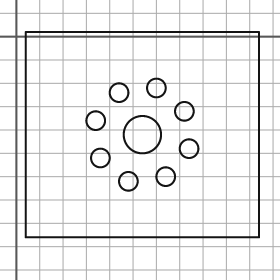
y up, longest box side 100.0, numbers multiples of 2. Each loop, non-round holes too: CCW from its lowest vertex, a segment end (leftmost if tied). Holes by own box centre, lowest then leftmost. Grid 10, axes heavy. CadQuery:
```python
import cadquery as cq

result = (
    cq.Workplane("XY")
    .moveTo(4.0, -86.0)
    .lineTo(104.0, -86.0)
    .lineTo(104.0, 2.0)
    .lineTo(4.0, 2.0)
    .close()
    .moveTo(48.0, -62.0)
    .circle(4.0)
    .moveTo(64.0, -60.0)
    .circle(4.0)
    .moveTo(36.0, -52.0)
    .circle(4.0)
    .moveTo(74.0, -48.0)
    .circle(4.0)
    .moveTo(54.0, -42.0)
    .circle(8.0)
    .moveTo(34.0, -36.0)
    .circle(4.0)
    .moveTo(72.0, -32.0)
    .circle(4.0)
    .moveTo(44.0, -24.0)
    .circle(4.0)
    .moveTo(60.0, -22.0)
    .circle(4.0)
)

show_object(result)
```